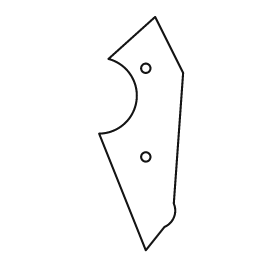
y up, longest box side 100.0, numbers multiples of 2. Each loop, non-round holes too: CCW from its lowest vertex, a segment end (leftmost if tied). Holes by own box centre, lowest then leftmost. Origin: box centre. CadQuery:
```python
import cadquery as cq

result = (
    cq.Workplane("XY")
    .moveTo(2.0, -50.0)
    .lineTo(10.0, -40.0)
    .threePointArc((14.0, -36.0), (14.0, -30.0))
    .lineTo(18.0, 26.0)
    .lineTo(6.0, 50.0)
    .lineTo(-14.0, 32.0)
    .threePointArc((-2.0, 14.0), (-18.0, 0.0))
    .close()
    .moveTo(2.0, -10.0)
    .circle(2.0)
    .moveTo(2.0, 28.0)
    .circle(2.0)
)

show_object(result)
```